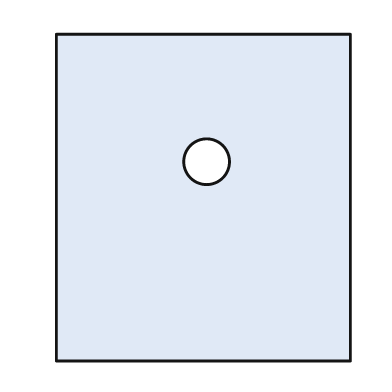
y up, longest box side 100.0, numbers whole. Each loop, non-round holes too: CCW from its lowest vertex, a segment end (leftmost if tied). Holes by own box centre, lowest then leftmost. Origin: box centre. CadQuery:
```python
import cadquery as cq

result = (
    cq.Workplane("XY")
    .moveTo(-45.0, -50.0)
    .lineTo(45.0, -50.0)
    .lineTo(45.0, 50.0)
    .lineTo(-45.0, 50.0)
    .close()
    .moveTo(1.0, 11.0)
    .circle(7.0)
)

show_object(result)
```